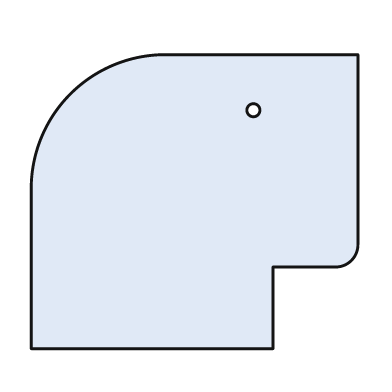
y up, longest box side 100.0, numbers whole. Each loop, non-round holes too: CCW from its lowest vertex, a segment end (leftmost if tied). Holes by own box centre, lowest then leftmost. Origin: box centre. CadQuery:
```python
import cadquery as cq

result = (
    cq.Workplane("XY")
    .moveTo(-50.0, -45.0)
    .lineTo(24.0, -45.0)
    .lineTo(24.0, -20.0)
    .lineTo(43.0, -20.0)
    .threePointArc((48.0, -18.0), (50.0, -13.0))
    .lineTo(50.0, 45.0)
    .lineTo(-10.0, 45.0)
    .threePointArc((-38.0, 33.0), (-50.0, 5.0))
    .close()
    .moveTo(18.0, 28.0)
    .circle(2.0)
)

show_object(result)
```